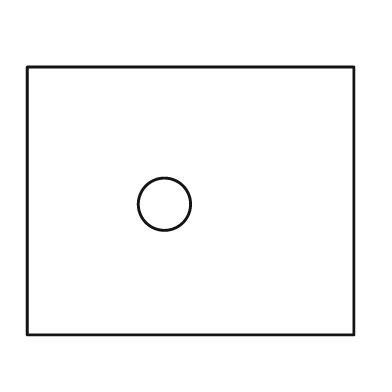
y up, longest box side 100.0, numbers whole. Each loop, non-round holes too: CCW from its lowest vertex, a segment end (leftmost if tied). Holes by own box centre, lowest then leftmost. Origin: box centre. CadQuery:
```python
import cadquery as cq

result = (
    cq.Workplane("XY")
    .moveTo(-50.0, -41.0)
    .lineTo(50.0, -41.0)
    .lineTo(50.0, 41.0)
    .lineTo(-50.0, 41.0)
    .close()
    .moveTo(-8.0, -1.0)
    .circle(8.0)
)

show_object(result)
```